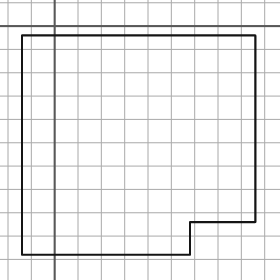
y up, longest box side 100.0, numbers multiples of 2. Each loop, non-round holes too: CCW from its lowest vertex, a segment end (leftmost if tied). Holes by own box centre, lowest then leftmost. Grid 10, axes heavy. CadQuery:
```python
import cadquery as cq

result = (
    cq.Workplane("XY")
    .moveTo(-14.0, -98.0)
    .lineTo(58.0, -98.0)
    .lineTo(58.0, -84.0)
    .lineTo(86.0, -84.0)
    .lineTo(86.0, -4.0)
    .lineTo(-14.0, -4.0)
    .close()
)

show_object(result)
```